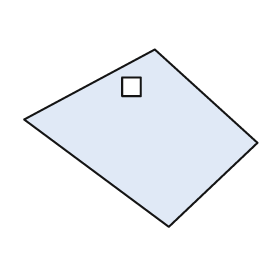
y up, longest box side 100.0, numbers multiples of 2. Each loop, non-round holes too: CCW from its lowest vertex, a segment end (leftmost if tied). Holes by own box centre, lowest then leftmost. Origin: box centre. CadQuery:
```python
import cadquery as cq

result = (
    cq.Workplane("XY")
    .moveTo(12.0, -38.0)
    .lineTo(50.0, -2.0)
    .lineTo(6.0, 38.0)
    .lineTo(-50.0, 8.0)
    .close()
    .moveTo(-8.0, 18.0)
    .lineTo(0.0, 18.0)
    .lineTo(0.0, 26.0)
    .lineTo(-8.0, 26.0)
    .close()
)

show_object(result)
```